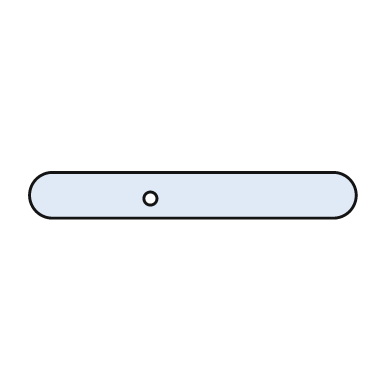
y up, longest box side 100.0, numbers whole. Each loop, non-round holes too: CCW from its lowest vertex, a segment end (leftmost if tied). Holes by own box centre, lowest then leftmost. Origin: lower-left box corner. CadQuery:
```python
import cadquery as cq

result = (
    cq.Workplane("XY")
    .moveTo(7.0, 0.0)
    .lineTo(93.0, 0.0)
    .threePointArc((100.0, 7.0), (93.0, 14.0))
    .lineTo(7.0, 14.0)
    .threePointArc((0.0, 7.0), (7.0, 0.0))
    .close()
    .moveTo(37.0, 6.0)
    .circle(2.0)
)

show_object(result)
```